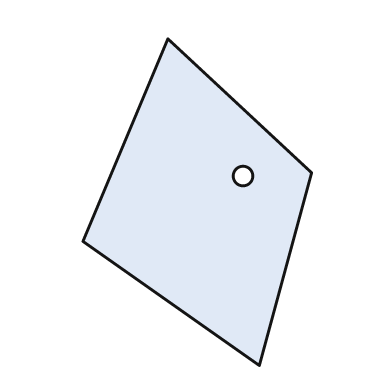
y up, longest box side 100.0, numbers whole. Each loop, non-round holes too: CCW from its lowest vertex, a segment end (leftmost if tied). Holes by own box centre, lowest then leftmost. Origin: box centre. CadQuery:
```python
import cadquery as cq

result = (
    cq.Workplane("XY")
    .moveTo(19.0, -50.0)
    .lineTo(35.0, 9.0)
    .lineTo(-9.0, 50.0)
    .lineTo(-35.0, -12.0)
    .close()
    .moveTo(14.0, 8.0)
    .circle(3.0)
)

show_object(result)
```